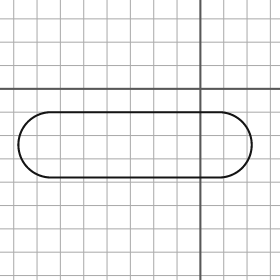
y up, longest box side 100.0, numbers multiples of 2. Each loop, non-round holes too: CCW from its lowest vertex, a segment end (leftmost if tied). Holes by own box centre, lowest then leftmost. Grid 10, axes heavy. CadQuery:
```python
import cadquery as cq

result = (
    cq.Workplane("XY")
    .moveTo(-64.0, -38.0)
    .lineTo(8.0, -38.0)
    .threePointArc((22.0, -24.0), (8.0, -10.0))
    .lineTo(-64.0, -10.0)
    .threePointArc((-78.0, -24.0), (-64.0, -38.0))
    .close()
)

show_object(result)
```